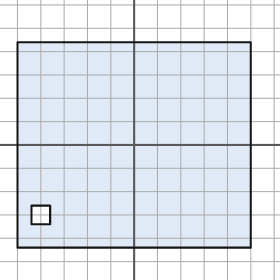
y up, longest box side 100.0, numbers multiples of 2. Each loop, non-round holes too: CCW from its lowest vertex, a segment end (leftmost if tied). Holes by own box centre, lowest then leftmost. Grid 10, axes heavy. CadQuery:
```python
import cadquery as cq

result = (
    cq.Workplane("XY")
    .moveTo(-50.0, -44.0)
    .lineTo(50.0, -44.0)
    .lineTo(50.0, 44.0)
    .lineTo(-50.0, 44.0)
    .close()
    .moveTo(-44.0, -34.0)
    .lineTo(-36.0, -34.0)
    .lineTo(-36.0, -26.0)
    .lineTo(-44.0, -26.0)
    .close()
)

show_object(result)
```